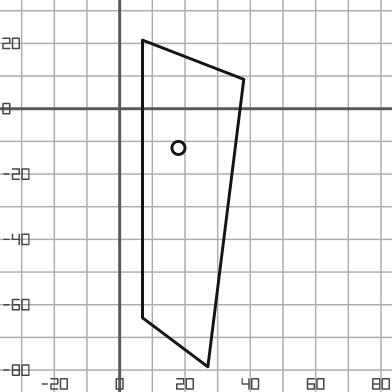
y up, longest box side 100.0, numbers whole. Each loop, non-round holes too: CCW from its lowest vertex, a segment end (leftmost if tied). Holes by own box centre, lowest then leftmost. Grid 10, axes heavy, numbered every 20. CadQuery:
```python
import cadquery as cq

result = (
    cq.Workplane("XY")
    .moveTo(27.0, -79.0)
    .lineTo(38.0, 9.0)
    .lineTo(7.0, 21.0)
    .lineTo(7.0, -64.0)
    .close()
    .moveTo(18.0, -12.0)
    .circle(2.0)
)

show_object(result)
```